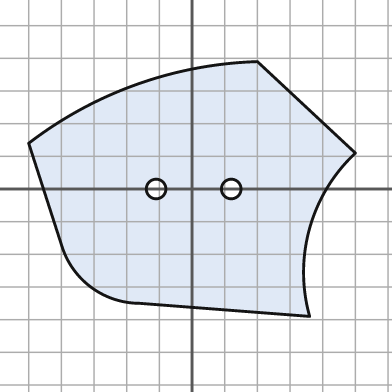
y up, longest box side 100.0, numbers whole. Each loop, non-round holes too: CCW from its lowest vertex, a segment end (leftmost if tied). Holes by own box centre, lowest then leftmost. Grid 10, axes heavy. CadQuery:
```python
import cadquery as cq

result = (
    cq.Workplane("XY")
    .moveTo(36.0, -39.0)
    .threePointArc((36.0, -12.0), (50.0, 11.0))
    .lineTo(20.0, 39.0)
    .threePointArc((-17.0, 32.0), (-50.0, 14.0))
    .lineTo(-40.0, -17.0)
    .threePointArc((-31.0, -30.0), (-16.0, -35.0))
    .close()
    .moveTo(-11.0, 0.0)
    .circle(3.0)
    .moveTo(12.0, 0.0)
    .circle(3.0)
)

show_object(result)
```